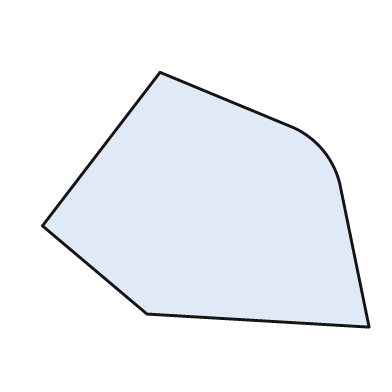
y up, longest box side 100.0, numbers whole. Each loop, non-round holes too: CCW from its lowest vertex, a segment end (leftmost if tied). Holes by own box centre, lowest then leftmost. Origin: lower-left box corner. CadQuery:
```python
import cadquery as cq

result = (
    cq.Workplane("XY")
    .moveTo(100.0, 0.0)
    .lineTo(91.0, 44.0)
    .threePointArc((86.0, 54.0), (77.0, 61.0))
    .lineTo(36.0, 78.0)
    .lineTo(0.0, 31.0)
    .lineTo(32.0, 4.0)
    .close()
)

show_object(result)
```